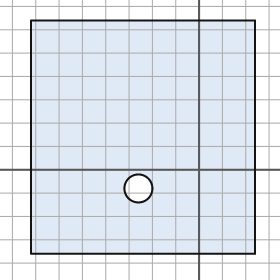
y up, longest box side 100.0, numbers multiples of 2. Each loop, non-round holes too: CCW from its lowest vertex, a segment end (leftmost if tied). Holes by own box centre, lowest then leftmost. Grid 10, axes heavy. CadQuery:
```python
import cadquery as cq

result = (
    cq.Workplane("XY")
    .moveTo(-72.0, -36.0)
    .lineTo(24.0, -36.0)
    .lineTo(24.0, 64.0)
    .lineTo(-72.0, 64.0)
    .close()
    .moveTo(-26.0, -8.0)
    .circle(6.0)
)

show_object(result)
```